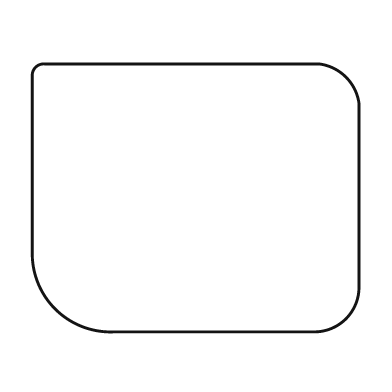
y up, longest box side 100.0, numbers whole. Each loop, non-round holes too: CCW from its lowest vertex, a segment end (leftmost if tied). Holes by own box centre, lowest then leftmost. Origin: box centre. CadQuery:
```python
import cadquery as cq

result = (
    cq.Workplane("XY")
    .moveTo(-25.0, -41.0)
    .lineTo(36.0, -41.0)
    .threePointArc((46.0, -37.0), (50.0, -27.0))
    .lineTo(50.0, 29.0)
    .threePointArc((46.0, 37.0), (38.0, 41.0))
    .lineTo(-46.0, 41.0)
    .threePointArc((-49.0, 40.0), (-50.0, 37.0))
    .lineTo(-50.0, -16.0)
    .threePointArc((-43.0, -34.0), (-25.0, -41.0))
    .close()
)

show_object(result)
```